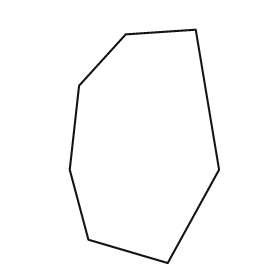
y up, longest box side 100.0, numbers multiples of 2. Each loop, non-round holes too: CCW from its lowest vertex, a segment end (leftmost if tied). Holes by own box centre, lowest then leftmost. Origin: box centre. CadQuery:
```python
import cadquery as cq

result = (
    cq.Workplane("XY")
    .moveTo(10.0, -50.0)
    .lineTo(32.0, -10.0)
    .lineTo(22.0, 50.0)
    .lineTo(-8.0, 48.0)
    .lineTo(-28.0, 26.0)
    .lineTo(-32.0, -10.0)
    .lineTo(-24.0, -40.0)
    .close()
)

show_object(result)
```